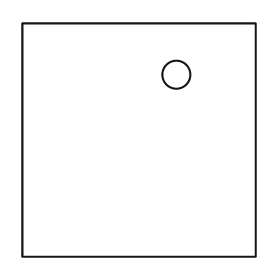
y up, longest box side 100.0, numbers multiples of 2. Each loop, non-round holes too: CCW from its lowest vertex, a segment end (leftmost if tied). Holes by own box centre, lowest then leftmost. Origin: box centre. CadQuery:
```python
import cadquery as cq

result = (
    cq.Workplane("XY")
    .moveTo(-50.0, -50.0)
    .lineTo(50.0, -50.0)
    .lineTo(50.0, 50.0)
    .lineTo(-50.0, 50.0)
    .close()
    .moveTo(16.0, 28.0)
    .circle(6.0)
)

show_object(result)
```